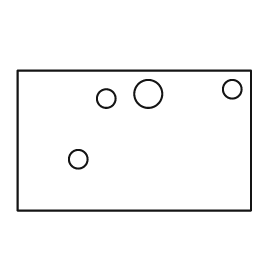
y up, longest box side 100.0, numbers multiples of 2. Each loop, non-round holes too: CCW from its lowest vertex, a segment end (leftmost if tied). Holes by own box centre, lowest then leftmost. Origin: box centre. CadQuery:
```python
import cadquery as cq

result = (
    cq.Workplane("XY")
    .moveTo(-50.0, -30.0)
    .lineTo(50.0, -30.0)
    .lineTo(50.0, 30.0)
    .lineTo(-50.0, 30.0)
    .close()
    .moveTo(-24.0, -8.0)
    .circle(4.0)
    .moveTo(-12.0, 18.0)
    .circle(4.0)
    .moveTo(6.0, 20.0)
    .circle(6.0)
    .moveTo(42.0, 22.0)
    .circle(4.0)
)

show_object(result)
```